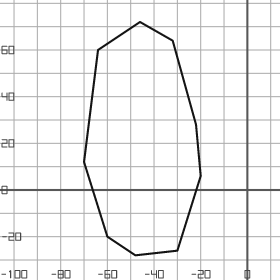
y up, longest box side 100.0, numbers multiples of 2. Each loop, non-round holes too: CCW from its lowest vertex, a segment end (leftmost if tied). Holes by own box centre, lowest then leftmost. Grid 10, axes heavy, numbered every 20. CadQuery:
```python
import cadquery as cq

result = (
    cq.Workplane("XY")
    .moveTo(-48.0, -28.0)
    .lineTo(-30.0, -26.0)
    .lineTo(-20.0, 6.0)
    .lineTo(-22.0, 28.0)
    .lineTo(-32.0, 64.0)
    .lineTo(-46.0, 72.0)
    .lineTo(-64.0, 60.0)
    .lineTo(-70.0, 12.0)
    .lineTo(-60.0, -20.0)
    .close()
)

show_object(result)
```